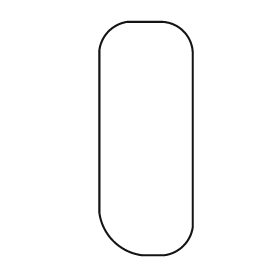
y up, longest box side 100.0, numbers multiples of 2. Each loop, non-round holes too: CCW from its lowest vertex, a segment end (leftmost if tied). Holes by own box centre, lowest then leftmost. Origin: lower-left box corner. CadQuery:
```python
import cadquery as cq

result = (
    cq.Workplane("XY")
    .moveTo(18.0, 0.0)
    .lineTo(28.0, 0.0)
    .threePointArc((36.0, 4.0), (40.0, 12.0))
    .lineTo(40.0, 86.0)
    .threePointArc((36.0, 96.0), (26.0, 100.0))
    .lineTo(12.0, 100.0)
    .threePointArc((4.0, 96.0), (0.0, 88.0))
    .lineTo(0.0, 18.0)
    .threePointArc((6.0, 6.0), (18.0, 0.0))
    .close()
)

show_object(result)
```